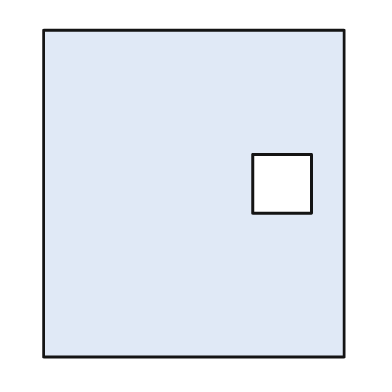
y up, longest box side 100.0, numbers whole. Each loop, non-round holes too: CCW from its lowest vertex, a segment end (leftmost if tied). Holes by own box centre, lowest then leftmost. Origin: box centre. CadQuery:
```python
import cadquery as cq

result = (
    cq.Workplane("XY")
    .moveTo(-46.0, -50.0)
    .lineTo(46.0, -50.0)
    .lineTo(46.0, 50.0)
    .lineTo(-46.0, 50.0)
    .close()
    .moveTo(18.0, -6.0)
    .lineTo(36.0, -6.0)
    .lineTo(36.0, 12.0)
    .lineTo(18.0, 12.0)
    .close()
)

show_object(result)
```